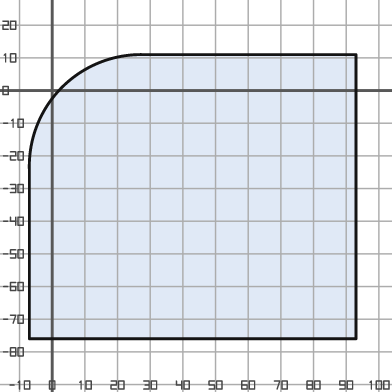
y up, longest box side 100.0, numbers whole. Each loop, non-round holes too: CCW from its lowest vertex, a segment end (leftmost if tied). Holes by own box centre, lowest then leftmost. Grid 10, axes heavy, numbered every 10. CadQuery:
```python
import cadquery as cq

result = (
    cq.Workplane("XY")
    .moveTo(-7.0, -76.0)
    .lineTo(93.0, -76.0)
    .lineTo(93.0, 11.0)
    .lineTo(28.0, 11.0)
    .threePointArc((3.0, 1.0), (-7.0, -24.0))
    .close()
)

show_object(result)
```